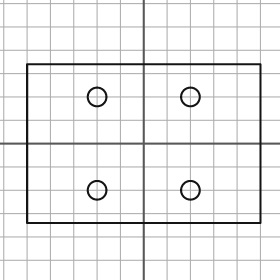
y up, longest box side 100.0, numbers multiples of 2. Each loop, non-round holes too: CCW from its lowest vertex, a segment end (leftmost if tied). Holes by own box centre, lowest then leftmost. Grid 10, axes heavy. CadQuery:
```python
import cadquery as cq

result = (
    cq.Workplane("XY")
    .moveTo(-50.0, -34.0)
    .lineTo(50.0, -34.0)
    .lineTo(50.0, 34.0)
    .lineTo(-50.0, 34.0)
    .close()
    .moveTo(-20.0, -20.0)
    .circle(4.0)
    .moveTo(20.0, -20.0)
    .circle(4.0)
    .moveTo(-20.0, 20.0)
    .circle(4.0)
    .moveTo(20.0, 20.0)
    .circle(4.0)
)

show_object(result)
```